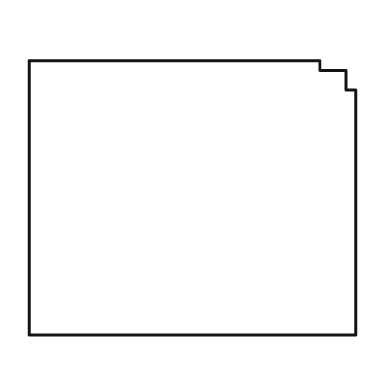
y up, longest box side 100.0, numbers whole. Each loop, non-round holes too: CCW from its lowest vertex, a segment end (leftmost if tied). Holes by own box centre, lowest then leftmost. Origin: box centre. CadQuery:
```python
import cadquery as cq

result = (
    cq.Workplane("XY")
    .moveTo(-50.0, -42.0)
    .lineTo(50.0, -42.0)
    .lineTo(50.0, 33.0)
    .lineTo(47.0, 33.0)
    .lineTo(47.0, 39.0)
    .lineTo(39.0, 39.0)
    .lineTo(39.0, 42.0)
    .lineTo(-50.0, 42.0)
    .close()
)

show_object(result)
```